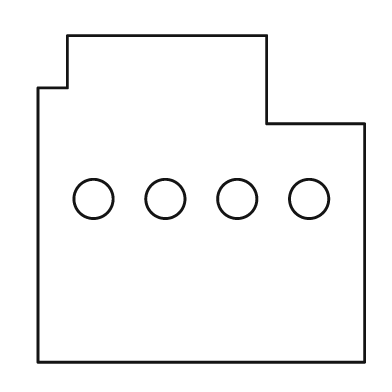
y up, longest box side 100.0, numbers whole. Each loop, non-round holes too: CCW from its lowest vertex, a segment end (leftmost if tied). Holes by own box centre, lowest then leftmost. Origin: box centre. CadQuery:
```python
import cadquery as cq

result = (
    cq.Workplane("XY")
    .moveTo(-50.0, -50.0)
    .lineTo(50.0, -50.0)
    .lineTo(50.0, 23.0)
    .lineTo(20.0, 23.0)
    .lineTo(20.0, 50.0)
    .lineTo(-41.0, 50.0)
    .lineTo(-41.0, 34.0)
    .lineTo(-50.0, 34.0)
    .close()
    .moveTo(-33.0, 0.0)
    .circle(6.0)
    .moveTo(-11.0, 0.0)
    .circle(6.0)
    .moveTo(11.0, 0.0)
    .circle(6.0)
    .moveTo(33.0, 0.0)
    .circle(6.0)
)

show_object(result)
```